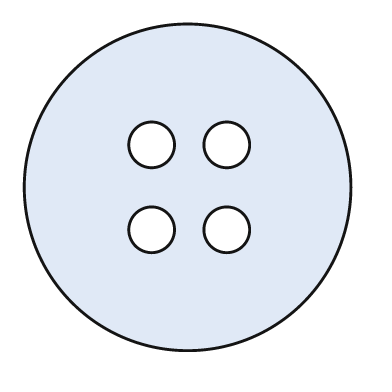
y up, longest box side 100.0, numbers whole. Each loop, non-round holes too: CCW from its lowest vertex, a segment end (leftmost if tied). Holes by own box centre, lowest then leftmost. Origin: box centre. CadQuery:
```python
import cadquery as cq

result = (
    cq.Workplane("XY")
    .moveTo(0.0, 0.0)
    .circle(50.0)
    .moveTo(-11.0, -13.0)
    .circle(7.0)
    .moveTo(12.0, -13.0)
    .circle(7.0)
    .moveTo(-11.0, 13.0)
    .circle(7.0)
    .moveTo(12.0, 13.0)
    .circle(7.0)
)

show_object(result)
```